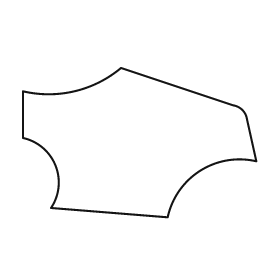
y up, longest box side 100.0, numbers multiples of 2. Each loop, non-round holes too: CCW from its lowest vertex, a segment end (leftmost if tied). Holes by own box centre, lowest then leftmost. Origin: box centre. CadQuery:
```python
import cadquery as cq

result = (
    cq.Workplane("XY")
    .moveTo(12.0, -32.0)
    .threePointArc((26.0, -12.0), (50.0, -8.0))
    .lineTo(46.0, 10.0)
    .threePointArc((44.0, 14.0), (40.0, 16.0))
    .lineTo(-8.0, 32.0)
    .threePointArc((-28.0, 22.0), (-50.0, 22.0))
    .lineTo(-50.0, 2.0)
    .threePointArc((-36.0, -10.0), (-38.0, -28.0))
    .close()
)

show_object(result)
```